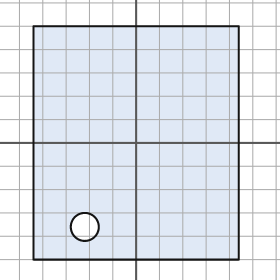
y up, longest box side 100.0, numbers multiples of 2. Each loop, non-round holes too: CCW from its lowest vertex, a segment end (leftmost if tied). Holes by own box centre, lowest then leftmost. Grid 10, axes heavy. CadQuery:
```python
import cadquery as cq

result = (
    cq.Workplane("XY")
    .moveTo(-44.0, -50.0)
    .lineTo(44.0, -50.0)
    .lineTo(44.0, 50.0)
    .lineTo(-44.0, 50.0)
    .close()
    .moveTo(-22.0, -36.0)
    .circle(6.0)
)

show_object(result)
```